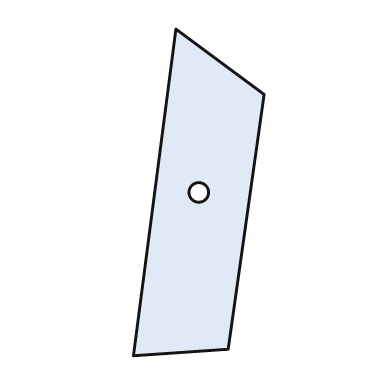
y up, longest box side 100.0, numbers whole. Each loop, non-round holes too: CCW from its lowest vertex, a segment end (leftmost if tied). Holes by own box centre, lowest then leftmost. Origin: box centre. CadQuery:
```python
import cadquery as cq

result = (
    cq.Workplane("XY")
    .moveTo(-20.0, -50.0)
    .lineTo(9.0, -48.0)
    .lineTo(20.0, 30.0)
    .lineTo(-7.0, 50.0)
    .close()
    .moveTo(0.0, 0.0)
    .circle(3.0)
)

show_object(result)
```